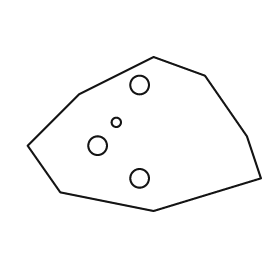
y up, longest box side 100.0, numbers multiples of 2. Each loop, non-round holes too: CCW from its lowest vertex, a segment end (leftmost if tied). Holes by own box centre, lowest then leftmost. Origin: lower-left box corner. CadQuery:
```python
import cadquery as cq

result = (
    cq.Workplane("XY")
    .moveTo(54.0, 0.0)
    .lineTo(100.0, 14.0)
    .lineTo(94.0, 32.0)
    .lineTo(76.0, 58.0)
    .lineTo(54.0, 66.0)
    .lineTo(22.0, 50.0)
    .lineTo(0.0, 28.0)
    .lineTo(14.0, 8.0)
    .close()
    .moveTo(48.0, 14.0)
    .circle(4.0)
    .moveTo(30.0, 28.0)
    .circle(4.0)
    .moveTo(38.0, 38.0)
    .circle(2.0)
    .moveTo(48.0, 54.0)
    .circle(4.0)
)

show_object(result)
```